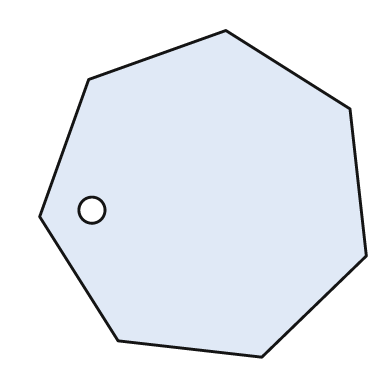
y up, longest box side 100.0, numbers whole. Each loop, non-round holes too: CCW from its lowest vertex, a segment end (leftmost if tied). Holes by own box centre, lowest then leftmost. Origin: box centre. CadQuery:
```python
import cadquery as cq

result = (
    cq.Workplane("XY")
    .moveTo(18.0, -50.0)
    .lineTo(50.0, -19.0)
    .lineTo(45.0, 26.0)
    .lineTo(7.0, 50.0)
    .lineTo(-35.0, 35.0)
    .lineTo(-50.0, -7.0)
    .lineTo(-26.0, -45.0)
    .close()
    .moveTo(-34.0, -5.0)
    .circle(4.0)
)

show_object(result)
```